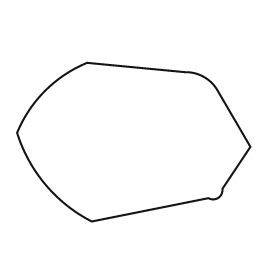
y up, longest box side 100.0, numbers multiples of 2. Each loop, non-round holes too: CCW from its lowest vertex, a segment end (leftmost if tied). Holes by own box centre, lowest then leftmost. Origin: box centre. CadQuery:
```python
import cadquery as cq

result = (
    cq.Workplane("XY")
    .moveTo(-18.0, -34.0)
    .lineTo(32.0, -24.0)
    .threePointArc((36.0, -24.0), (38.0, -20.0))
    .lineTo(50.0, -2.0)
    .lineTo(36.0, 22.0)
    .threePointArc((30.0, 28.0), (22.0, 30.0))
    .lineTo(-20.0, 34.0)
    .threePointArc((-38.0, 22.0), (-50.0, 4.0))
    .threePointArc((-38.0, -18.0), (-18.0, -34.0))
    .close()
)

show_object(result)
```